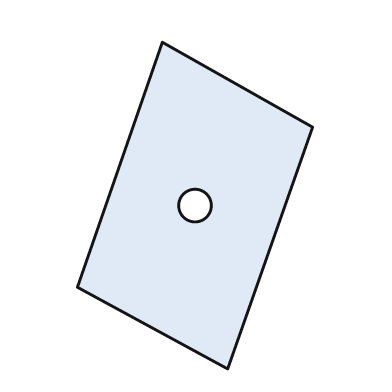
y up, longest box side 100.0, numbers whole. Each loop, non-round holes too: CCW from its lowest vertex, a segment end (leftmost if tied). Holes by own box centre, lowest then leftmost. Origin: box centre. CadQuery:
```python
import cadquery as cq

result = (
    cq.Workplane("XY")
    .moveTo(10.0, -50.0)
    .lineTo(36.0, 24.0)
    .lineTo(-10.0, 50.0)
    .lineTo(-36.0, -25.0)
    .close()
    .moveTo(0.0, 0.0)
    .circle(5.0)
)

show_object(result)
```